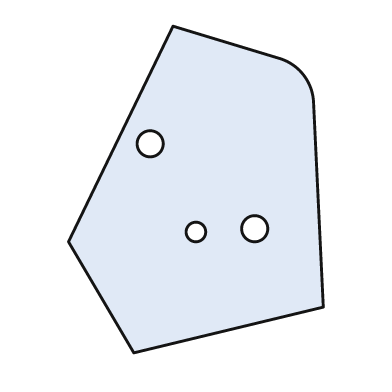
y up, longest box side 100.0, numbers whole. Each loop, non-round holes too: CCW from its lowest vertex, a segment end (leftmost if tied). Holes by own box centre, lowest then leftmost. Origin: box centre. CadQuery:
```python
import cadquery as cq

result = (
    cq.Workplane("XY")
    .moveTo(-19.0, -50.0)
    .lineTo(39.0, -36.0)
    .lineTo(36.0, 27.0)
    .threePointArc((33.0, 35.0), (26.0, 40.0))
    .lineTo(-7.0, 50.0)
    .lineTo(-39.0, -16.0)
    .close()
    .moveTo(0.0, -13.0)
    .circle(3.0)
    .moveTo(18.0, -12.0)
    .circle(4.0)
    .moveTo(-14.0, 14.0)
    .circle(4.0)
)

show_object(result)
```